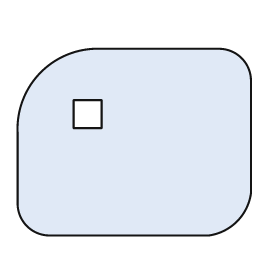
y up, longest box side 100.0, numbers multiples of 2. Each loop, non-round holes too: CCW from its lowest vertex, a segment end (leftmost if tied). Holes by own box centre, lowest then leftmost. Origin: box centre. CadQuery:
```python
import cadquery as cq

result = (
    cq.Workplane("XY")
    .moveTo(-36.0, -40.0)
    .lineTo(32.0, -40.0)
    .threePointArc((44.0, -34.0), (50.0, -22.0))
    .lineTo(50.0, 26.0)
    .threePointArc((46.0, 36.0), (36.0, 40.0))
    .lineTo(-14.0, 40.0)
    .threePointArc((-40.0, 30.0), (-50.0, 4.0))
    .lineTo(-50.0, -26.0)
    .threePointArc((-46.0, -36.0), (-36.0, -40.0))
    .close()
    .moveTo(-26.0, 6.0)
    .lineTo(-14.0, 6.0)
    .lineTo(-14.0, 18.0)
    .lineTo(-26.0, 18.0)
    .close()
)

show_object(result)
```